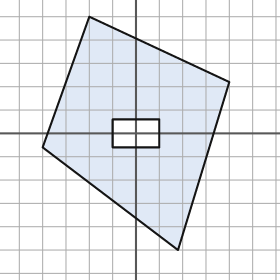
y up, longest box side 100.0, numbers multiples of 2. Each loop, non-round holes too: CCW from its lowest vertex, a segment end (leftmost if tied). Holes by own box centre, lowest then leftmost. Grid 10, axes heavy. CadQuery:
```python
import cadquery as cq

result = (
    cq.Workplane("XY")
    .moveTo(18.0, -50.0)
    .lineTo(40.0, 22.0)
    .lineTo(-20.0, 50.0)
    .lineTo(-40.0, -6.0)
    .close()
    .moveTo(-10.0, -6.0)
    .lineTo(10.0, -6.0)
    .lineTo(10.0, 6.0)
    .lineTo(-10.0, 6.0)
    .close()
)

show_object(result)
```